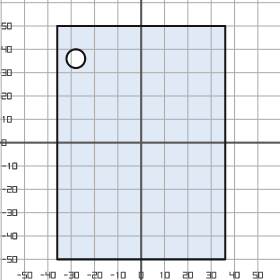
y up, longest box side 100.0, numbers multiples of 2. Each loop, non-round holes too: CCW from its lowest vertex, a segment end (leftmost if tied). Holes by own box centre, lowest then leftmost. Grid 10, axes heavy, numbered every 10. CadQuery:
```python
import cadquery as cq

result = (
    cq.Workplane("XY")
    .moveTo(-36.0, -50.0)
    .lineTo(36.0, -50.0)
    .lineTo(36.0, 50.0)
    .lineTo(-36.0, 50.0)
    .close()
    .moveTo(-28.0, 36.0)
    .circle(4.0)
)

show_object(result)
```